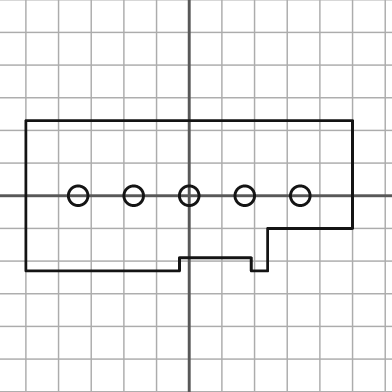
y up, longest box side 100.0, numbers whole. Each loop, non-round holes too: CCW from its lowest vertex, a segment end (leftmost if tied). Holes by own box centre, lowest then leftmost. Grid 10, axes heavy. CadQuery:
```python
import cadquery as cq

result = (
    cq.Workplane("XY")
    .moveTo(-50.0, -23.0)
    .lineTo(-3.0, -23.0)
    .lineTo(-3.0, -19.0)
    .lineTo(19.0, -19.0)
    .lineTo(19.0, -23.0)
    .lineTo(24.0, -23.0)
    .lineTo(24.0, -10.0)
    .lineTo(50.0, -10.0)
    .lineTo(50.0, 23.0)
    .lineTo(-50.0, 23.0)
    .close()
    .moveTo(-34.0, 0.0)
    .circle(3.0)
    .moveTo(-17.0, 0.0)
    .circle(3.0)
    .moveTo(0.0, 0.0)
    .circle(3.0)
    .moveTo(17.0, 0.0)
    .circle(3.0)
    .moveTo(34.0, 0.0)
    .circle(3.0)
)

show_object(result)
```